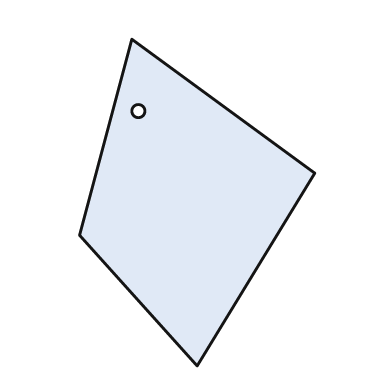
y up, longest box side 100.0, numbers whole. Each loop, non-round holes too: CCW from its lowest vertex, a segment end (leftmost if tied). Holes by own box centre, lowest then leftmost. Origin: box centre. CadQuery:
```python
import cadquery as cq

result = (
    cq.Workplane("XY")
    .moveTo(0.0, -50.0)
    .lineTo(36.0, 9.0)
    .lineTo(-20.0, 50.0)
    .lineTo(-36.0, -10.0)
    .close()
    .moveTo(-18.0, 28.0)
    .circle(2.0)
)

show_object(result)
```